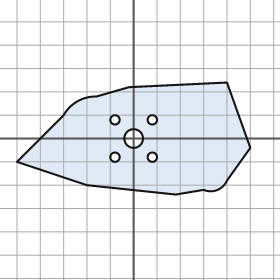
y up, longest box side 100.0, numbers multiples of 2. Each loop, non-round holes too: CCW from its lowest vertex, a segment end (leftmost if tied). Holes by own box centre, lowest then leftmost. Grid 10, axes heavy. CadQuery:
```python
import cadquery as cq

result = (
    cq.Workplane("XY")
    .moveTo(18.0, -24.0)
    .lineTo(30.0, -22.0)
    .threePointArc((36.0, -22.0), (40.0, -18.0))
    .lineTo(50.0, -4.0)
    .lineTo(40.0, 24.0)
    .lineTo(-2.0, 22.0)
    .lineTo(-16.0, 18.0)
    .threePointArc((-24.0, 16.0), (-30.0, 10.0))
    .lineTo(-50.0, -10.0)
    .lineTo(-20.0, -20.0)
    .close()
    .moveTo(-8.0, -8.0)
    .circle(2.0)
    .moveTo(8.0, -8.0)
    .circle(2.0)
    .moveTo(0.0, 0.0)
    .circle(4.0)
    .moveTo(-8.0, 8.0)
    .circle(2.0)
    .moveTo(8.0, 8.0)
    .circle(2.0)
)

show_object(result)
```